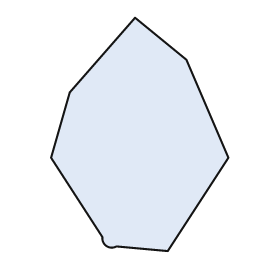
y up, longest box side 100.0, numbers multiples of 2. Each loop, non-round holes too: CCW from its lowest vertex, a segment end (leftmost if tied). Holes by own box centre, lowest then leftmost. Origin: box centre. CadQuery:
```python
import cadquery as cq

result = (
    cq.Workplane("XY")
    .moveTo(12.0, -50.0)
    .lineTo(38.0, -10.0)
    .lineTo(20.0, 32.0)
    .lineTo(-2.0, 50.0)
    .lineTo(-30.0, 18.0)
    .lineTo(-38.0, -10.0)
    .lineTo(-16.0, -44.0)
    .threePointArc((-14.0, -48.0), (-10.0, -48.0))
    .close()
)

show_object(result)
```